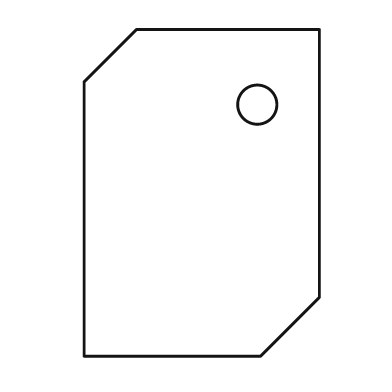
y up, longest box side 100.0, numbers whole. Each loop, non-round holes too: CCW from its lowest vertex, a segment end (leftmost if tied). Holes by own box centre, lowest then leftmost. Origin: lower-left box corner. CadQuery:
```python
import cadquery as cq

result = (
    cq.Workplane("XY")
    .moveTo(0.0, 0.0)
    .lineTo(54.0, 0.0)
    .lineTo(72.0, 18.0)
    .lineTo(72.0, 100.0)
    .lineTo(16.0, 100.0)
    .lineTo(0.0, 84.0)
    .close()
    .moveTo(53.0, 77.0)
    .circle(6.0)
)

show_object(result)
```